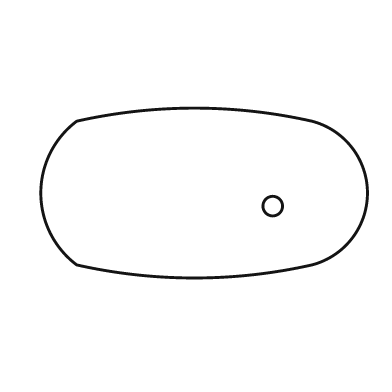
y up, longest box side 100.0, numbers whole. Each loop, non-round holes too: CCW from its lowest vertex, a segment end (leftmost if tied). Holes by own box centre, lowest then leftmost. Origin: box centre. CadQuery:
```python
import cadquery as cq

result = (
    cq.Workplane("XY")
    .moveTo(-39.0, -22.0)
    .threePointArc((-3.0, -26.0), (33.0, -22.0))
    .threePointArc((50.0, 0.0), (33.0, 22.0))
    .threePointArc((-3.0, 26.0), (-39.0, 22.0))
    .threePointArc((-50.0, 0.0), (-39.0, -22.0))
    .close()
    .moveTo(21.0, -4.0)
    .circle(3.0)
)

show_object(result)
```